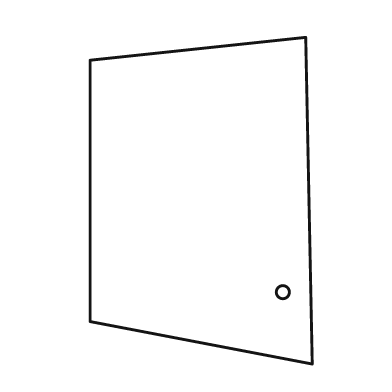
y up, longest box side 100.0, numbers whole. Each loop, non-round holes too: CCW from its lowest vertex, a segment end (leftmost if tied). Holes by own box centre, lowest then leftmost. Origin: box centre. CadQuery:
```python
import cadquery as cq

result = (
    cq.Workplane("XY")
    .moveTo(34.0, -50.0)
    .lineTo(32.0, 50.0)
    .lineTo(-34.0, 43.0)
    .lineTo(-34.0, -37.0)
    .close()
    .moveTo(25.0, -28.0)
    .circle(2.0)
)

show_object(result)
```